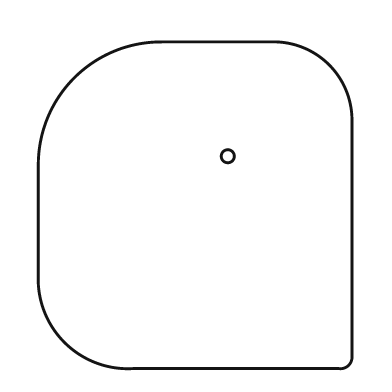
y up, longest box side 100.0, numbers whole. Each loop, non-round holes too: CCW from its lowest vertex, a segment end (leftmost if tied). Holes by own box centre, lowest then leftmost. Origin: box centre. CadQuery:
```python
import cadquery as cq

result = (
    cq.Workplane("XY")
    .moveTo(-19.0, -50.0)
    .lineTo(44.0, -50.0)
    .threePointArc((47.0, -49.0), (48.0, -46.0))
    .lineTo(48.0, 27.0)
    .threePointArc((41.0, 43.0), (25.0, 50.0))
    .lineTo(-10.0, 50.0)
    .threePointArc((-37.0, 39.0), (-48.0, 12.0))
    .lineTo(-48.0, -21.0)
    .threePointArc((-40.0, -42.0), (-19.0, -50.0))
    .close()
    .moveTo(10.0, 15.0)
    .circle(2.0)
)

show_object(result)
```